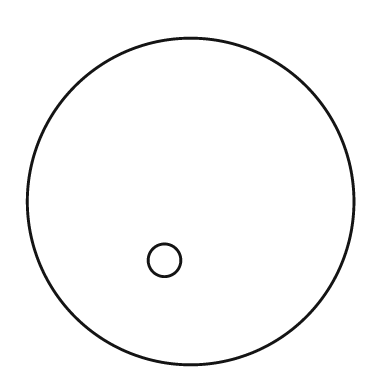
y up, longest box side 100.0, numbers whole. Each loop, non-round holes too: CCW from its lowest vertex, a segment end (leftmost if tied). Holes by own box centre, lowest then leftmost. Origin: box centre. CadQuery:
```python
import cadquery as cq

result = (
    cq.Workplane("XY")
    .moveTo(0.0, 0.0)
    .circle(50.0)
    .moveTo(-8.0, -18.0)
    .circle(5.0)
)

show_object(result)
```